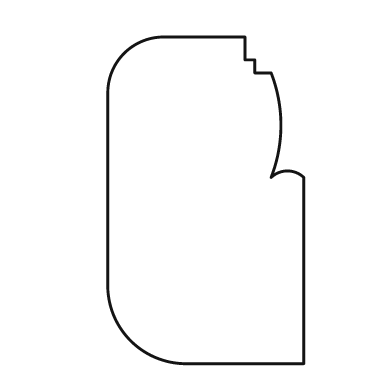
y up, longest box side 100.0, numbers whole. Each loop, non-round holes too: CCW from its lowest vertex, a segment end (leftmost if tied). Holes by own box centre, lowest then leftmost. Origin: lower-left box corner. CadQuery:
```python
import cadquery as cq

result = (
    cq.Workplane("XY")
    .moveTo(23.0, 0.0)
    .lineTo(60.0, 0.0)
    .lineTo(60.0, 57.0)
    .threePointArc((55.0, 59.0), (50.0, 57.0))
    .threePointArc((53.0, 73.0), (50.0, 89.0))
    .lineTo(45.0, 89.0)
    .lineTo(45.0, 93.0)
    .lineTo(42.0, 93.0)
    .lineTo(42.0, 100.0)
    .lineTo(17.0, 100.0)
    .threePointArc((5.0, 95.0), (0.0, 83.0))
    .lineTo(0.0, 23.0)
    .threePointArc((7.0, 7.0), (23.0, 0.0))
    .close()
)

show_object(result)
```